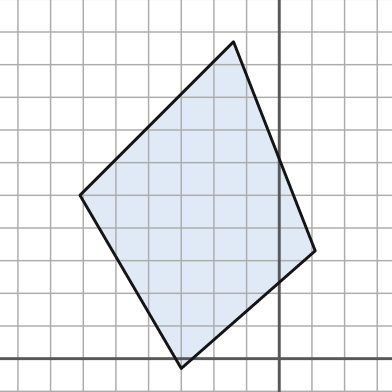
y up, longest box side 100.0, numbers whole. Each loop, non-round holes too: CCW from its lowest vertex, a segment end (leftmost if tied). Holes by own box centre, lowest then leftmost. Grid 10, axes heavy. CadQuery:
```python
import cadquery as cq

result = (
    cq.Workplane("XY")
    .moveTo(-30.0, -3.0)
    .lineTo(11.0, 33.0)
    .lineTo(-14.0, 97.0)
    .lineTo(-61.0, 50.0)
    .close()
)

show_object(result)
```